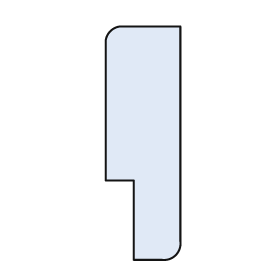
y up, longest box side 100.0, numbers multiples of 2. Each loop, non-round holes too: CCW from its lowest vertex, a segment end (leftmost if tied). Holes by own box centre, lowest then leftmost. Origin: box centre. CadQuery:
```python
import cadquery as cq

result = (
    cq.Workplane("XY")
    .moveTo(-4.0, -50.0)
    .lineTo(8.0, -50.0)
    .threePointArc((14.0, -48.0), (16.0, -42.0))
    .lineTo(16.0, 50.0)
    .lineTo(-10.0, 50.0)
    .threePointArc((-14.0, 48.0), (-16.0, 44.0))
    .lineTo(-16.0, -16.0)
    .lineTo(-4.0, -16.0)
    .close()
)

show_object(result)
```